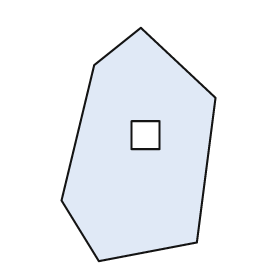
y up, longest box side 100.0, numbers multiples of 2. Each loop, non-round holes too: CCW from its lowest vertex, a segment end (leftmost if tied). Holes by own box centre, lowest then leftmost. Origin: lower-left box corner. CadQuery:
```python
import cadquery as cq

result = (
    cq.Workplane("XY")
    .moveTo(16.0, 0.0)
    .lineTo(58.0, 8.0)
    .lineTo(66.0, 70.0)
    .lineTo(34.0, 100.0)
    .lineTo(14.0, 84.0)
    .lineTo(0.0, 26.0)
    .close()
    .moveTo(30.0, 48.0)
    .lineTo(42.0, 48.0)
    .lineTo(42.0, 60.0)
    .lineTo(30.0, 60.0)
    .close()
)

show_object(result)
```